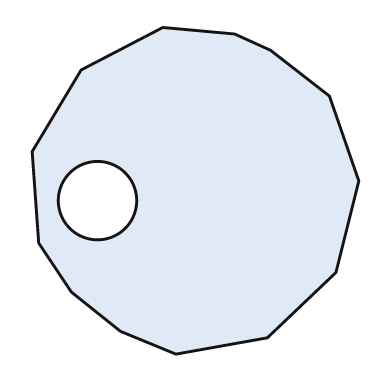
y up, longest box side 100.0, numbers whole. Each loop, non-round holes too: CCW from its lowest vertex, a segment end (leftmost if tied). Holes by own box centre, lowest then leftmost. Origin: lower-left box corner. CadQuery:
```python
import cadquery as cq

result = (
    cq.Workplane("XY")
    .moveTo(44.0, 0.0)
    .lineTo(72.0, 5.0)
    .lineTo(93.0, 25.0)
    .lineTo(100.0, 53.0)
    .lineTo(91.0, 79.0)
    .lineTo(73.0, 93.0)
    .lineTo(62.0, 98.0)
    .lineTo(40.0, 100.0)
    .lineTo(15.0, 87.0)
    .lineTo(0.0, 62.0)
    .lineTo(2.0, 34.0)
    .lineTo(12.0, 19.0)
    .lineTo(27.0, 7.0)
    .close()
    .moveTo(20.0, 47.0)
    .circle(12.0)
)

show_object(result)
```